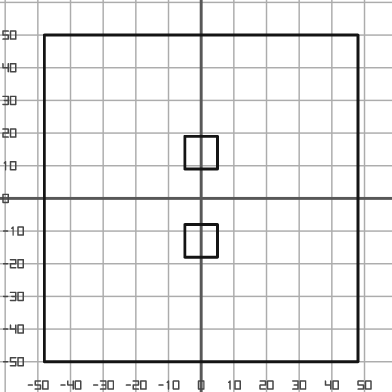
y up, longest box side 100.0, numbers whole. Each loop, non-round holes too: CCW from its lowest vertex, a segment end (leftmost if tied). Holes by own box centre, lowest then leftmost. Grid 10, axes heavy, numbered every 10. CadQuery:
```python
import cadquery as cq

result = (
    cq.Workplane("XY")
    .moveTo(-48.0, -50.0)
    .lineTo(48.0, -50.0)
    .lineTo(48.0, 50.0)
    .lineTo(-48.0, 50.0)
    .close()
    .moveTo(-5.0, -18.0)
    .lineTo(5.0, -18.0)
    .lineTo(5.0, -8.0)
    .lineTo(-5.0, -8.0)
    .close()
    .moveTo(-5.0, 9.0)
    .lineTo(5.0, 9.0)
    .lineTo(5.0, 19.0)
    .lineTo(-5.0, 19.0)
    .close()
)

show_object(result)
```